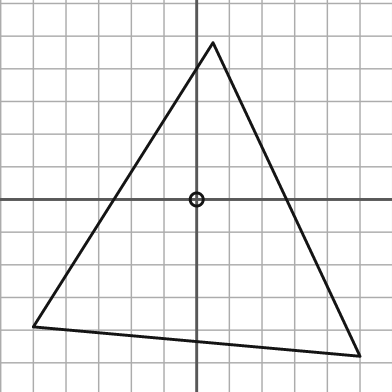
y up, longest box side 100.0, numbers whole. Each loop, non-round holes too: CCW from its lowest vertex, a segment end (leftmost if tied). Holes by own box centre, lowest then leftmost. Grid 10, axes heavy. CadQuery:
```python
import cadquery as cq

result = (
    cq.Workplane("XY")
    .moveTo(50.0, -48.0)
    .lineTo(5.0, 48.0)
    .lineTo(-50.0, -39.0)
    .close()
    .moveTo(0.0, 0.0)
    .circle(2.0)
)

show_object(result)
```